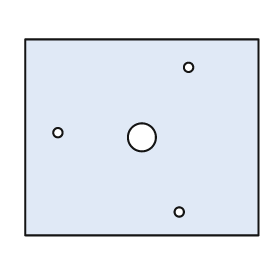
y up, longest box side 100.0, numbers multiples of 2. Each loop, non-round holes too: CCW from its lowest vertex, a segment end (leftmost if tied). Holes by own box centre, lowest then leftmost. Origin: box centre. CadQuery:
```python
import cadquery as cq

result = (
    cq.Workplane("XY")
    .moveTo(-50.0, -42.0)
    .lineTo(50.0, -42.0)
    .lineTo(50.0, 42.0)
    .lineTo(-50.0, 42.0)
    .close()
    .moveTo(16.0, -32.0)
    .circle(2.0)
    .moveTo(0.0, 0.0)
    .circle(6.0)
    .moveTo(-36.0, 2.0)
    .circle(2.0)
    .moveTo(20.0, 30.0)
    .circle(2.0)
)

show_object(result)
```